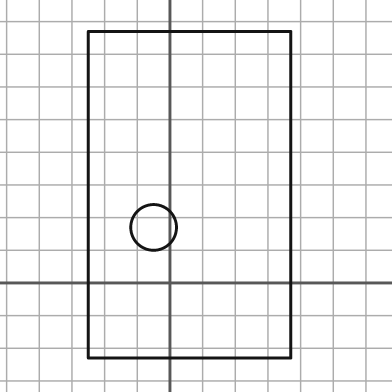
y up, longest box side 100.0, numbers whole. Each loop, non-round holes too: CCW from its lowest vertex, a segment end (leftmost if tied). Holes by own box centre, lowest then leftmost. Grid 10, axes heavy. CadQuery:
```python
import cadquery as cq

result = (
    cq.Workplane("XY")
    .moveTo(-25.0, -23.0)
    .lineTo(37.0, -23.0)
    .lineTo(37.0, 77.0)
    .lineTo(-25.0, 77.0)
    .close()
    .moveTo(-5.0, 17.0)
    .circle(7.0)
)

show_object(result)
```